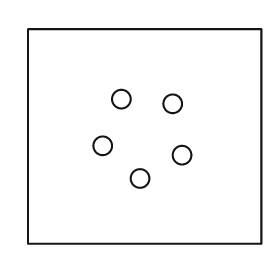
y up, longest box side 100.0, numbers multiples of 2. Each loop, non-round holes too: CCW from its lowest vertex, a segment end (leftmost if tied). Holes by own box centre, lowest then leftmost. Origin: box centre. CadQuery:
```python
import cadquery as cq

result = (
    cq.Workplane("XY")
    .moveTo(-50.0, -46.0)
    .lineTo(50.0, -46.0)
    .lineTo(50.0, 46.0)
    .lineTo(-50.0, 46.0)
    .close()
    .moveTo(-2.0, -18.0)
    .circle(4.0)
    .moveTo(16.0, -8.0)
    .circle(4.0)
    .moveTo(-18.0, -4.0)
    .circle(4.0)
    .moveTo(12.0, 14.0)
    .circle(4.0)
    .moveTo(-10.0, 16.0)
    .circle(4.0)
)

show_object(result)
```